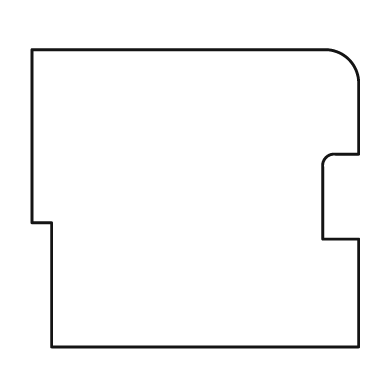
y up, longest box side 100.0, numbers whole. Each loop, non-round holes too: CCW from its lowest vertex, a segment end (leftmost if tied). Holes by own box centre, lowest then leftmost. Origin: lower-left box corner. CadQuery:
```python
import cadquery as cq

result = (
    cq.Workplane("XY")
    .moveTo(6.0, 0.0)
    .lineTo(100.0, 0.0)
    .lineTo(100.0, 33.0)
    .lineTo(89.0, 33.0)
    .lineTo(89.0, 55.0)
    .threePointArc((90.0, 58.0), (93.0, 59.0))
    .lineTo(100.0, 59.0)
    .lineTo(100.0, 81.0)
    .threePointArc((97.0, 88.0), (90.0, 91.0))
    .lineTo(0.0, 91.0)
    .lineTo(0.0, 38.0)
    .lineTo(6.0, 38.0)
    .close()
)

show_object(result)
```